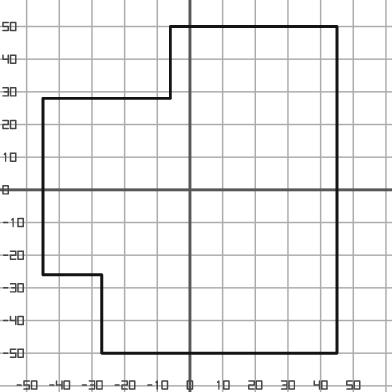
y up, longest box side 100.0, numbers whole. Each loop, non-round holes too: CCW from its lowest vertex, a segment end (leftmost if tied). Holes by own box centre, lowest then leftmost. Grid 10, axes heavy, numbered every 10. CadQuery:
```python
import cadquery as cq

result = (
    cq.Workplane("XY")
    .moveTo(-27.0, -50.0)
    .lineTo(45.0, -50.0)
    .lineTo(45.0, 50.0)
    .lineTo(-6.0, 50.0)
    .lineTo(-6.0, 28.0)
    .lineTo(-45.0, 28.0)
    .lineTo(-45.0, -26.0)
    .lineTo(-27.0, -26.0)
    .close()
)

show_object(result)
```